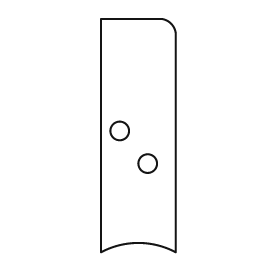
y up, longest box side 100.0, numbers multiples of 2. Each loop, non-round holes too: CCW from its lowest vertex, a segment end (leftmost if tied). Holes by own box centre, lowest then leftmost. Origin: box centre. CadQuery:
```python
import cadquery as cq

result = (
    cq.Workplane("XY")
    .moveTo(-16.0, -50.0)
    .threePointArc((0.0, -46.0), (16.0, -50.0))
    .lineTo(16.0, 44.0)
    .threePointArc((14.0, 48.0), (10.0, 50.0))
    .lineTo(-16.0, 50.0)
    .close()
    .moveTo(4.0, -12.0)
    .circle(4.0)
    .moveTo(-8.0, 2.0)
    .circle(4.0)
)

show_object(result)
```